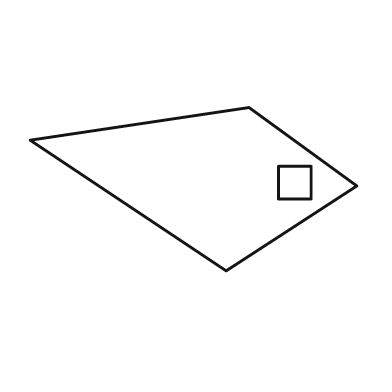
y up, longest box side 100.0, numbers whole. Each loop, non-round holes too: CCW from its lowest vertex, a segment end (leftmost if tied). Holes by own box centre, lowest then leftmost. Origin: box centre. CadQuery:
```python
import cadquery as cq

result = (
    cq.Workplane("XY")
    .moveTo(10.0, -25.0)
    .lineTo(50.0, 1.0)
    .lineTo(17.0, 25.0)
    .lineTo(-50.0, 15.0)
    .close()
    .moveTo(26.0, -3.0)
    .lineTo(36.0, -3.0)
    .lineTo(36.0, 7.0)
    .lineTo(26.0, 7.0)
    .close()
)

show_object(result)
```